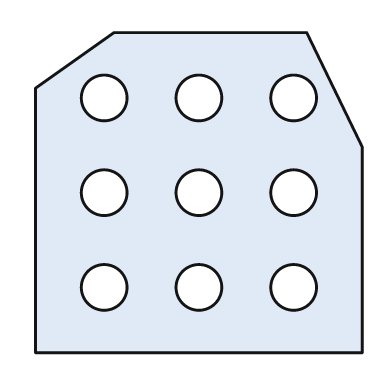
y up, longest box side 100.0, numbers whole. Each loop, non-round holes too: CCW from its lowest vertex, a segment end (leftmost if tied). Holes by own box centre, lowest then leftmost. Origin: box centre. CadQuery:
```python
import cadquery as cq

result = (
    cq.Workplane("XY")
    .moveTo(-50.0, -49.0)
    .lineTo(50.0, -49.0)
    .lineTo(50.0, 14.0)
    .lineTo(33.0, 49.0)
    .lineTo(-26.0, 49.0)
    .lineTo(-50.0, 32.0)
    .close()
    .moveTo(-29.0, -29.0)
    .circle(7.0)
    .moveTo(0.0, -29.0)
    .circle(7.0)
    .moveTo(29.0, -29.0)
    .circle(7.0)
    .moveTo(-29.0, 0.0)
    .circle(7.0)
    .moveTo(0.0, 0.0)
    .circle(7.0)
    .moveTo(29.0, 0.0)
    .circle(7.0)
    .moveTo(-29.0, 29.0)
    .circle(7.0)
    .moveTo(0.0, 29.0)
    .circle(7.0)
    .moveTo(29.0, 29.0)
    .circle(7.0)
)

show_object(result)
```